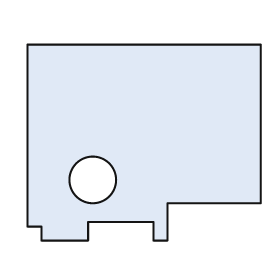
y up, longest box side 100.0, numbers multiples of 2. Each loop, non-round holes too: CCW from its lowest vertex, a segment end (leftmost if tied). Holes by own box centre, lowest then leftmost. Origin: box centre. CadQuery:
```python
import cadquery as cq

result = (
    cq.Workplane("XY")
    .moveTo(-44.0, -42.0)
    .lineTo(-24.0, -42.0)
    .lineTo(-24.0, -34.0)
    .lineTo(4.0, -34.0)
    .lineTo(4.0, -42.0)
    .lineTo(10.0, -42.0)
    .lineTo(10.0, -26.0)
    .lineTo(50.0, -26.0)
    .lineTo(50.0, 42.0)
    .lineTo(-50.0, 42.0)
    .lineTo(-50.0, -36.0)
    .lineTo(-44.0, -36.0)
    .close()
    .moveTo(-22.0, -16.0)
    .circle(10.0)
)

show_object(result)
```